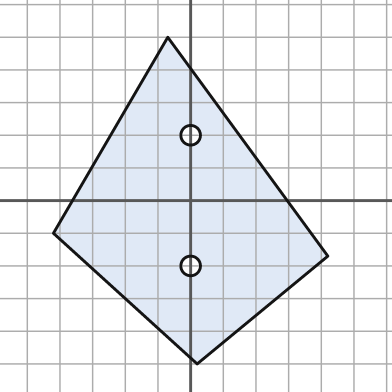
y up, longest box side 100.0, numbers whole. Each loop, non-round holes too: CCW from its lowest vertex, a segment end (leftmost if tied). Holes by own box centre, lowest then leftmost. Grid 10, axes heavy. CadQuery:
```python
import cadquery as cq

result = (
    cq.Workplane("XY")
    .moveTo(2.0, -50.0)
    .lineTo(42.0, -17.0)
    .lineTo(-7.0, 50.0)
    .lineTo(-42.0, -10.0)
    .close()
    .moveTo(0.0, -20.0)
    .circle(3.0)
    .moveTo(0.0, 20.0)
    .circle(3.0)
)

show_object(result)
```